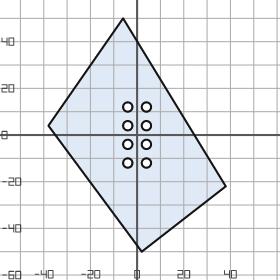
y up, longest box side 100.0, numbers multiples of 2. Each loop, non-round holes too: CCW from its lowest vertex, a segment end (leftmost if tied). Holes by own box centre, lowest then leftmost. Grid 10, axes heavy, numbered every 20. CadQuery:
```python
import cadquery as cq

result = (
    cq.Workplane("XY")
    .moveTo(2.0, -50.0)
    .lineTo(38.0, -22.0)
    .lineTo(-6.0, 50.0)
    .lineTo(-38.0, 4.0)
    .close()
    .moveTo(-4.0, -12.0)
    .circle(2.0)
    .moveTo(4.0, -12.0)
    .circle(2.0)
    .moveTo(-4.0, -4.0)
    .circle(2.0)
    .moveTo(4.0, -4.0)
    .circle(2.0)
    .moveTo(-4.0, 4.0)
    .circle(2.0)
    .moveTo(4.0, 4.0)
    .circle(2.0)
    .moveTo(-4.0, 12.0)
    .circle(2.0)
    .moveTo(4.0, 12.0)
    .circle(2.0)
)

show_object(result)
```